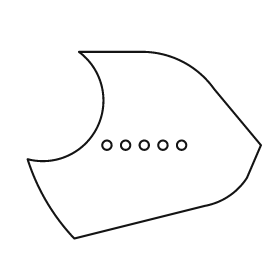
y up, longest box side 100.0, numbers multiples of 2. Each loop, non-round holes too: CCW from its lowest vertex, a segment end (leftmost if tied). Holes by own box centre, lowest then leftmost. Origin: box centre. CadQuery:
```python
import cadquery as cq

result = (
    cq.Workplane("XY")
    .moveTo(-30.0, -40.0)
    .lineTo(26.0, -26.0)
    .threePointArc((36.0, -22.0), (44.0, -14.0))
    .lineTo(50.0, 0.0)
    .lineTo(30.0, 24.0)
    .threePointArc((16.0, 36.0), (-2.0, 40.0))
    .lineTo(-28.0, 40.0)
    .threePointArc((-20.0, 8.0), (-50.0, -6.0))
    .threePointArc((-42.0, -24.0), (-30.0, -40.0))
    .close()
    .moveTo(-16.0, 0.0)
    .circle(2.0)
    .moveTo(-8.0, 0.0)
    .circle(2.0)
    .moveTo(0.0, 0.0)
    .circle(2.0)
    .moveTo(8.0, 0.0)
    .circle(2.0)
    .moveTo(16.0, 0.0)
    .circle(2.0)
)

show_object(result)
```